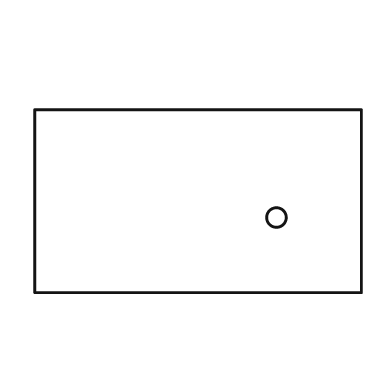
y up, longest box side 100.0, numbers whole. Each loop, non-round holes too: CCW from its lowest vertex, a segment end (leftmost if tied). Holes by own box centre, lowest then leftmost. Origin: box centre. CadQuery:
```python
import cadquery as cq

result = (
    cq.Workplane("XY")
    .moveTo(-50.0, -28.0)
    .lineTo(50.0, -28.0)
    .lineTo(50.0, 28.0)
    .lineTo(-50.0, 28.0)
    .close()
    .moveTo(24.0, -5.0)
    .circle(3.0)
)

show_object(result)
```